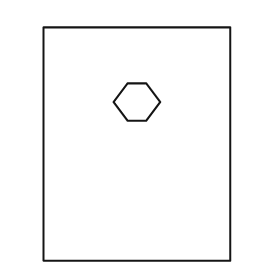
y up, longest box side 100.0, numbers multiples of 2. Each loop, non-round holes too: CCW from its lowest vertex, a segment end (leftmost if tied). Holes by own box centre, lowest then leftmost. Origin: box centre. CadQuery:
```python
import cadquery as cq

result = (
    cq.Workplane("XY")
    .moveTo(-40.0, -50.0)
    .lineTo(40.0, -50.0)
    .lineTo(40.0, 50.0)
    .lineTo(-40.0, 50.0)
    .close()
    .moveTo(-4.0, 10.0)
    .lineTo(4.0, 10.0)
    .lineTo(10.0, 18.0)
    .lineTo(4.0, 26.0)
    .lineTo(-4.0, 26.0)
    .lineTo(-10.0, 18.0)
    .close()
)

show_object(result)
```